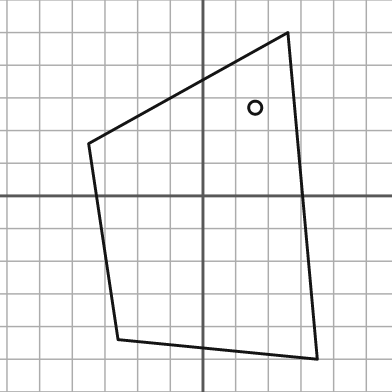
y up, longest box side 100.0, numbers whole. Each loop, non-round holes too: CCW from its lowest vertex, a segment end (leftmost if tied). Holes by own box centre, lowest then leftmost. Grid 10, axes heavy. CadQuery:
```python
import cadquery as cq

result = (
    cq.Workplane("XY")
    .moveTo(35.0, -50.0)
    .lineTo(26.0, 50.0)
    .lineTo(-35.0, 16.0)
    .lineTo(-26.0, -44.0)
    .close()
    .moveTo(16.0, 27.0)
    .circle(2.0)
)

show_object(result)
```